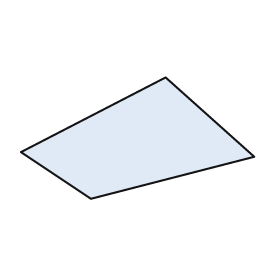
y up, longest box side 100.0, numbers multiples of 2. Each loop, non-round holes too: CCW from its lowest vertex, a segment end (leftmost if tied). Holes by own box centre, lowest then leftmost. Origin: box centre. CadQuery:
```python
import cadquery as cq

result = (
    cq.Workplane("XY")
    .moveTo(-20.0, -26.0)
    .lineTo(50.0, -8.0)
    .lineTo(12.0, 26.0)
    .lineTo(-50.0, -6.0)
    .close()
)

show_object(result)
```